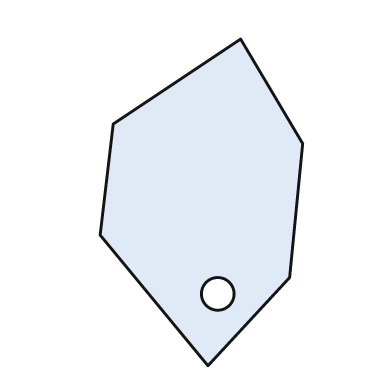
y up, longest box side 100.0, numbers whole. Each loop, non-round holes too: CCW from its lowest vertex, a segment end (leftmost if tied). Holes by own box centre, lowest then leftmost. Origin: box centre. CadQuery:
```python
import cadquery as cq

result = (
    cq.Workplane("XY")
    .moveTo(2.0, -50.0)
    .lineTo(27.0, -23.0)
    .lineTo(31.0, 18.0)
    .lineTo(12.0, 50.0)
    .lineTo(-27.0, 24.0)
    .lineTo(-31.0, -10.0)
    .close()
    .moveTo(5.0, -28.0)
    .circle(5.0)
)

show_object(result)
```